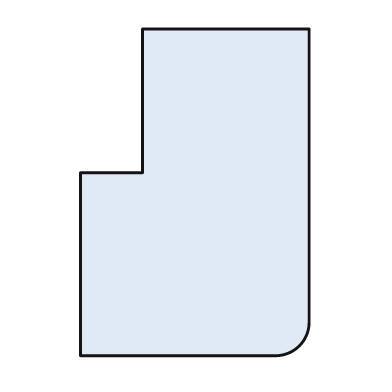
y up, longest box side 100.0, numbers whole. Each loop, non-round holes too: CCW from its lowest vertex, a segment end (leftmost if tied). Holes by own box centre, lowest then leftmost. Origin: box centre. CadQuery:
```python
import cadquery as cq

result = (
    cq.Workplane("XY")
    .moveTo(-35.0, -50.0)
    .lineTo(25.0, -50.0)
    .threePointArc((32.0, -47.0), (35.0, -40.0))
    .lineTo(35.0, 50.0)
    .lineTo(-16.0, 50.0)
    .lineTo(-16.0, 6.0)
    .lineTo(-35.0, 6.0)
    .close()
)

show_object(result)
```